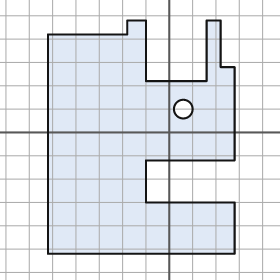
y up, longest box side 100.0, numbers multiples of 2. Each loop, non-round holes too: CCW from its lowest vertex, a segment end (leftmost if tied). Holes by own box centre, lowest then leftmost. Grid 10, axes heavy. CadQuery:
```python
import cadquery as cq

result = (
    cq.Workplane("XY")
    .moveTo(-52.0, -52.0)
    .lineTo(28.0, -52.0)
    .lineTo(28.0, -30.0)
    .lineTo(-10.0, -30.0)
    .lineTo(-10.0, -12.0)
    .lineTo(28.0, -12.0)
    .lineTo(28.0, 28.0)
    .lineTo(22.0, 28.0)
    .lineTo(22.0, 48.0)
    .lineTo(16.0, 48.0)
    .lineTo(16.0, 22.0)
    .lineTo(-10.0, 22.0)
    .lineTo(-10.0, 48.0)
    .lineTo(-18.0, 48.0)
    .lineTo(-18.0, 42.0)
    .lineTo(-52.0, 42.0)
    .close()
    .moveTo(6.0, 10.0)
    .circle(4.0)
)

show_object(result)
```